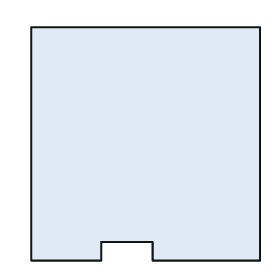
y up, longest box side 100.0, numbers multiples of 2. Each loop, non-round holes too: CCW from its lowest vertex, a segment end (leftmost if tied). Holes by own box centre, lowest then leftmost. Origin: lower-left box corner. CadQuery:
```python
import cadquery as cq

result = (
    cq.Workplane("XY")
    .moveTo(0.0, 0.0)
    .lineTo(30.0, 0.0)
    .lineTo(30.0, 8.0)
    .lineTo(52.0, 8.0)
    .lineTo(52.0, 0.0)
    .lineTo(98.0, 0.0)
    .lineTo(98.0, 100.0)
    .lineTo(0.0, 100.0)
    .close()
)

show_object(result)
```